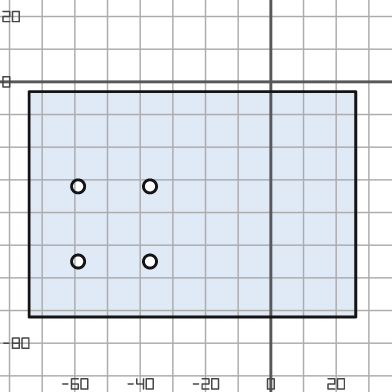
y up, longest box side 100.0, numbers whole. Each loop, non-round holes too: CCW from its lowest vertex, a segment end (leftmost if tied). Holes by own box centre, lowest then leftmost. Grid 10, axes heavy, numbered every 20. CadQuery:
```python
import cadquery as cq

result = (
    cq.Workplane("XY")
    .moveTo(-74.0, -72.0)
    .lineTo(26.0, -72.0)
    .lineTo(26.0, -3.0)
    .lineTo(-74.0, -3.0)
    .close()
    .moveTo(-59.0, -55.0)
    .circle(2.0)
    .moveTo(-37.0, -55.0)
    .circle(2.0)
    .moveTo(-59.0, -32.0)
    .circle(2.0)
    .moveTo(-37.0, -32.0)
    .circle(2.0)
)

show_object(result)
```